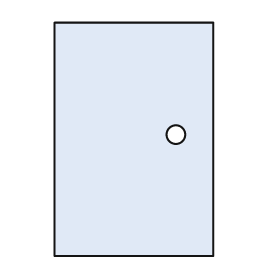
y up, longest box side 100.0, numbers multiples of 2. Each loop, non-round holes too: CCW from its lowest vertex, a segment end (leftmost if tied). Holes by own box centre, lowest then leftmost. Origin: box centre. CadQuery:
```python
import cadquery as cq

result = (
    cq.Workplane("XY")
    .moveTo(-34.0, -50.0)
    .lineTo(34.0, -50.0)
    .lineTo(34.0, 50.0)
    .lineTo(-34.0, 50.0)
    .close()
    .moveTo(18.0, 2.0)
    .circle(4.0)
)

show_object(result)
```